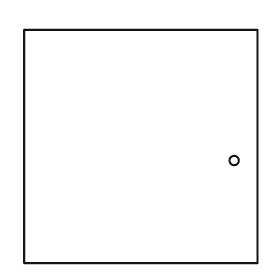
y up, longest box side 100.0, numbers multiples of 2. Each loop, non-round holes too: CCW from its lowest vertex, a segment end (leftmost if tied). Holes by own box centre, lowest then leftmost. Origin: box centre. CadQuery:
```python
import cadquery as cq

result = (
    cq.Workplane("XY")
    .moveTo(-50.0, -50.0)
    .lineTo(50.0, -50.0)
    .lineTo(50.0, 50.0)
    .lineTo(-50.0, 50.0)
    .close()
    .moveTo(40.0, -6.0)
    .circle(2.0)
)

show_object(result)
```